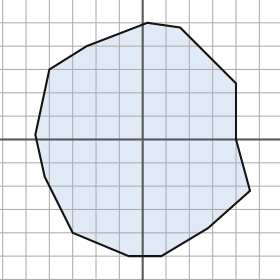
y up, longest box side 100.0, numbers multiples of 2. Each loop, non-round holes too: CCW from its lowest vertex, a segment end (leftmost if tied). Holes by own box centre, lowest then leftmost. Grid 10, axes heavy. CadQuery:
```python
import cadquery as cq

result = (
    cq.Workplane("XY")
    .moveTo(-6.0, -50.0)
    .lineTo(8.0, -50.0)
    .lineTo(28.0, -38.0)
    .lineTo(46.0, -22.0)
    .lineTo(40.0, 0.0)
    .lineTo(40.0, 24.0)
    .lineTo(16.0, 48.0)
    .lineTo(2.0, 50.0)
    .lineTo(-24.0, 40.0)
    .lineTo(-40.0, 30.0)
    .lineTo(-46.0, 2.0)
    .lineTo(-42.0, -16.0)
    .lineTo(-30.0, -40.0)
    .close()
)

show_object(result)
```